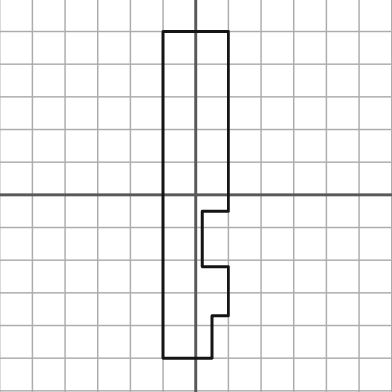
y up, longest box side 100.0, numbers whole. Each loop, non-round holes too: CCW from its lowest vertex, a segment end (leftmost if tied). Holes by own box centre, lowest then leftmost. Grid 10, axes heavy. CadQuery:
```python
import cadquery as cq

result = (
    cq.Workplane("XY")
    .moveTo(-10.0, -50.0)
    .lineTo(5.0, -50.0)
    .lineTo(5.0, -37.0)
    .lineTo(10.0, -37.0)
    .lineTo(10.0, -22.0)
    .lineTo(2.0, -22.0)
    .lineTo(2.0, -5.0)
    .lineTo(10.0, -5.0)
    .lineTo(10.0, 50.0)
    .lineTo(-10.0, 50.0)
    .close()
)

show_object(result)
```